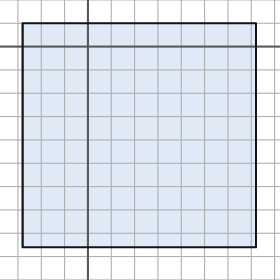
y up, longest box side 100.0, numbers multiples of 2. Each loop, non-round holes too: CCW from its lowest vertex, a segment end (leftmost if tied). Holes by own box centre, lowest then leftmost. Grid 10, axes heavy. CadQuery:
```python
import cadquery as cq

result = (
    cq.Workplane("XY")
    .moveTo(-28.0, -86.0)
    .lineTo(72.0, -86.0)
    .lineTo(72.0, 10.0)
    .lineTo(-28.0, 10.0)
    .close()
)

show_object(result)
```